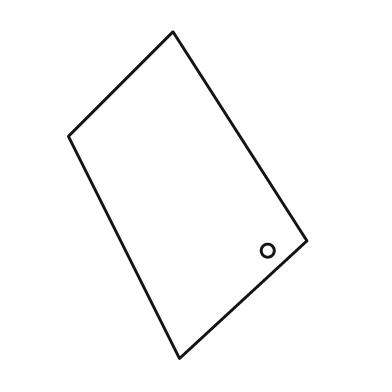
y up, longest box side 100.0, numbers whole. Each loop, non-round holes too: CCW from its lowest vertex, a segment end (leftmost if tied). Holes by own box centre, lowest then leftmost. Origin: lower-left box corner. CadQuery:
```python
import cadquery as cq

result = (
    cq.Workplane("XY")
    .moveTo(34.0, 0.0)
    .lineTo(73.0, 36.0)
    .lineTo(32.0, 100.0)
    .lineTo(0.0, 68.0)
    .close()
    .moveTo(61.0, 33.0)
    .circle(2.0)
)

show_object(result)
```